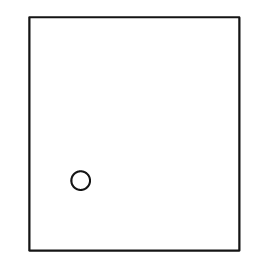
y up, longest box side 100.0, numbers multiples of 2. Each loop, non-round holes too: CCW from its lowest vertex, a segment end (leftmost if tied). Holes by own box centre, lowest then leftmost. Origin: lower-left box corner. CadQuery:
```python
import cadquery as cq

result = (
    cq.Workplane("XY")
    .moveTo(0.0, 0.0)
    .lineTo(90.0, 0.0)
    .lineTo(90.0, 100.0)
    .lineTo(0.0, 100.0)
    .close()
    .moveTo(22.0, 30.0)
    .circle(4.0)
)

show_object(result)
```